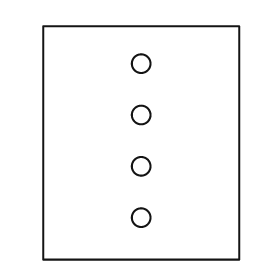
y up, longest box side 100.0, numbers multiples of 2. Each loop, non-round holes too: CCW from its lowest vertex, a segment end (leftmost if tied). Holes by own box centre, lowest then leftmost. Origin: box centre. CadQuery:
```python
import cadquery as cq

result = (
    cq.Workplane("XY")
    .moveTo(-42.0, -50.0)
    .lineTo(42.0, -50.0)
    .lineTo(42.0, 50.0)
    .lineTo(-42.0, 50.0)
    .close()
    .moveTo(0.0, -32.0)
    .circle(4.0)
    .moveTo(0.0, -10.0)
    .circle(4.0)
    .moveTo(0.0, 12.0)
    .circle(4.0)
    .moveTo(0.0, 34.0)
    .circle(4.0)
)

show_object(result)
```